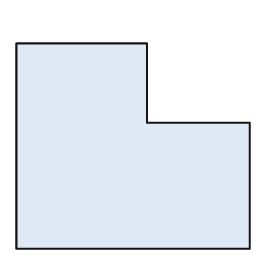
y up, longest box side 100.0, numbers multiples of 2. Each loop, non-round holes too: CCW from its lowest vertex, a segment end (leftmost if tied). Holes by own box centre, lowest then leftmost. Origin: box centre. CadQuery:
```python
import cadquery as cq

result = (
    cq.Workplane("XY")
    .moveTo(-50.0, -44.0)
    .lineTo(50.0, -44.0)
    .lineTo(50.0, 10.0)
    .lineTo(6.0, 10.0)
    .lineTo(6.0, 44.0)
    .lineTo(-50.0, 44.0)
    .close()
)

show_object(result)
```